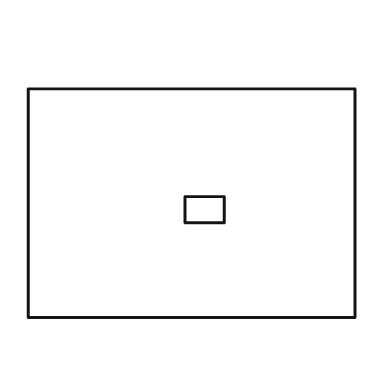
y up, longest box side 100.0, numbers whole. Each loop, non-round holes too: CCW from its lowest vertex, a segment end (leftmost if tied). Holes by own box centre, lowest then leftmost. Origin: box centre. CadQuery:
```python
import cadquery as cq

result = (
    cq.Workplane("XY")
    .moveTo(-50.0, -35.0)
    .lineTo(50.0, -35.0)
    .lineTo(50.0, 35.0)
    .lineTo(-50.0, 35.0)
    .close()
    .moveTo(-2.0, -6.0)
    .lineTo(10.0, -6.0)
    .lineTo(10.0, 2.0)
    .lineTo(-2.0, 2.0)
    .close()
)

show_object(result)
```